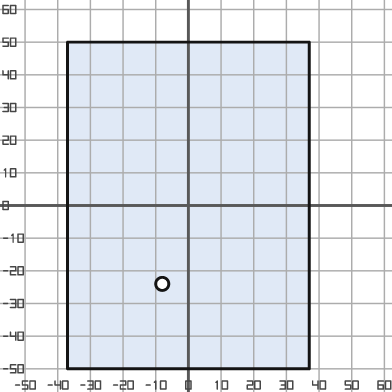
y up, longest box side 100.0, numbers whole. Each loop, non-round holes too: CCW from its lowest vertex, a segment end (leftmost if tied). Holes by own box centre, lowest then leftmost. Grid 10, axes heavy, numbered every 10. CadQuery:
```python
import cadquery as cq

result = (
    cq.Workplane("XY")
    .moveTo(-37.0, -50.0)
    .lineTo(37.0, -50.0)
    .lineTo(37.0, 50.0)
    .lineTo(-37.0, 50.0)
    .close()
    .moveTo(-8.0, -24.0)
    .circle(2.0)
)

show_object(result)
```